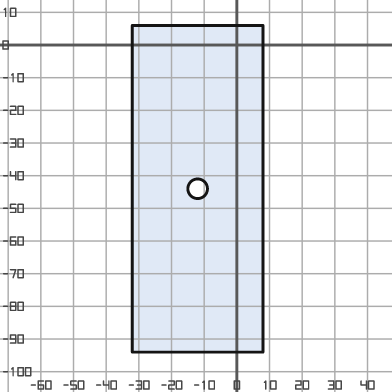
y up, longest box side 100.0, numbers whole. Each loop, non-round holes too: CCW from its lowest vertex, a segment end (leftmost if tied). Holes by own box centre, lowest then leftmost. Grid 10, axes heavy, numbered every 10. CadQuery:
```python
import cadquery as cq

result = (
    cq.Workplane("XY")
    .moveTo(-32.0, -94.0)
    .lineTo(8.0, -94.0)
    .lineTo(8.0, 6.0)
    .lineTo(-32.0, 6.0)
    .close()
    .moveTo(-12.0, -44.0)
    .circle(3.0)
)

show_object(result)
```